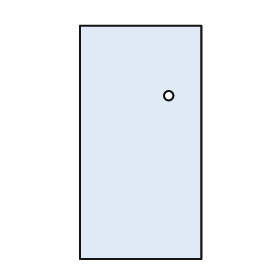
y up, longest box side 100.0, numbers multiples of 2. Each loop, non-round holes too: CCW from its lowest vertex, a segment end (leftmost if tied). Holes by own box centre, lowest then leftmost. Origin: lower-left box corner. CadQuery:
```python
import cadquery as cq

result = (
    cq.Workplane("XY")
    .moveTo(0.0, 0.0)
    .lineTo(52.0, 0.0)
    .lineTo(52.0, 100.0)
    .lineTo(0.0, 100.0)
    .close()
    .moveTo(38.0, 70.0)
    .circle(2.0)
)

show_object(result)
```